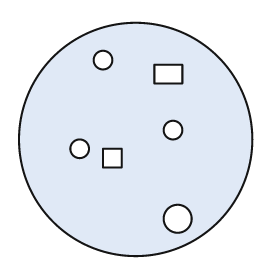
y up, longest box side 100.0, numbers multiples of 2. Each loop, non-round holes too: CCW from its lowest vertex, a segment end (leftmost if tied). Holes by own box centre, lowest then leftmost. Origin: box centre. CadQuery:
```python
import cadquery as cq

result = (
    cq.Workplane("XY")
    .moveTo(0.0, 0.0)
    .circle(50.0)
    .moveTo(18.0, -34.0)
    .circle(6.0)
    .moveTo(-14.0, -12.0)
    .lineTo(-6.0, -12.0)
    .lineTo(-6.0, -4.0)
    .lineTo(-14.0, -4.0)
    .close()
    .moveTo(-24.0, -4.0)
    .circle(4.0)
    .moveTo(16.0, 4.0)
    .circle(4.0)
    .moveTo(8.0, 24.0)
    .lineTo(20.0, 24.0)
    .lineTo(20.0, 32.0)
    .lineTo(8.0, 32.0)
    .close()
    .moveTo(-14.0, 34.0)
    .circle(4.0)
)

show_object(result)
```